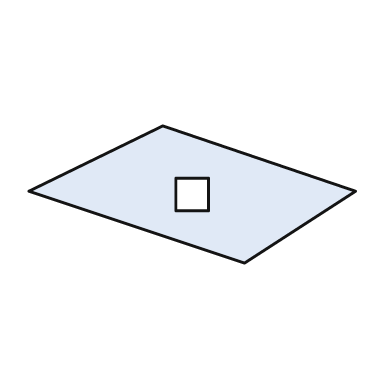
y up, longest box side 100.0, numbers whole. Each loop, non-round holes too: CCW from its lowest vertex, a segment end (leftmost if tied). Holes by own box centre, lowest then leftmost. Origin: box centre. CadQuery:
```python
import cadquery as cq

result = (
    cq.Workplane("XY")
    .moveTo(16.0, -21.0)
    .lineTo(50.0, 1.0)
    .lineTo(-9.0, 21.0)
    .lineTo(-50.0, 1.0)
    .close()
    .moveTo(-5.0, -5.0)
    .lineTo(5.0, -5.0)
    .lineTo(5.0, 5.0)
    .lineTo(-5.0, 5.0)
    .close()
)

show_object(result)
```